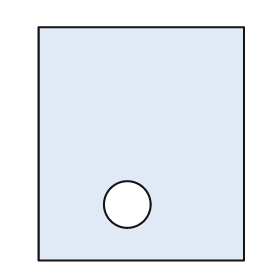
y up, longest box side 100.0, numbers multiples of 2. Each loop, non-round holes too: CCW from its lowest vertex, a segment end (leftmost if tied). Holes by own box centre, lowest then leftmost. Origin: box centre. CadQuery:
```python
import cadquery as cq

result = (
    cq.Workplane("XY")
    .moveTo(-44.0, -50.0)
    .lineTo(44.0, -50.0)
    .lineTo(44.0, 50.0)
    .lineTo(-44.0, 50.0)
    .close()
    .moveTo(-6.0, -26.0)
    .circle(10.0)
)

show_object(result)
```